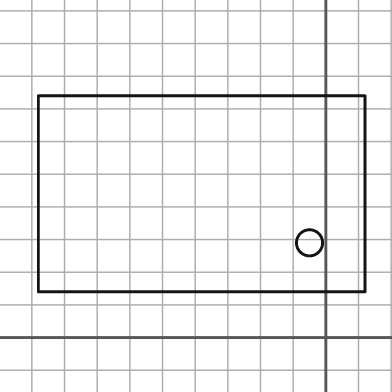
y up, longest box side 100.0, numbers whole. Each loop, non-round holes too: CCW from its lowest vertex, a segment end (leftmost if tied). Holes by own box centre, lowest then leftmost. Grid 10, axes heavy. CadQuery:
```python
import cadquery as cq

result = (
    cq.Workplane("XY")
    .moveTo(-88.0, 14.0)
    .lineTo(12.0, 14.0)
    .lineTo(12.0, 74.0)
    .lineTo(-88.0, 74.0)
    .close()
    .moveTo(-5.0, 29.0)
    .circle(4.0)
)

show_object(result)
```